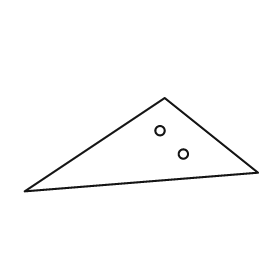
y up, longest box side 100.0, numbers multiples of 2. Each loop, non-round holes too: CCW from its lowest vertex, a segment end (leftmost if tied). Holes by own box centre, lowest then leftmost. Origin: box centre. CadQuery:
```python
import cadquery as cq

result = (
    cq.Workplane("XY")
    .moveTo(-50.0, -20.0)
    .lineTo(50.0, -12.0)
    .lineTo(10.0, 20.0)
    .close()
    .moveTo(18.0, -4.0)
    .circle(2.0)
    .moveTo(8.0, 6.0)
    .circle(2.0)
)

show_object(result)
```